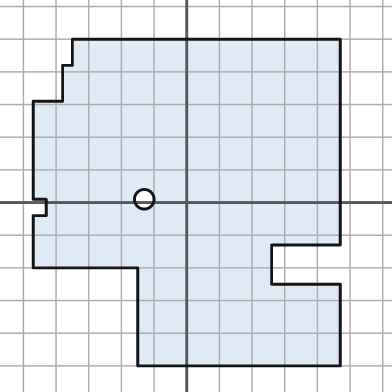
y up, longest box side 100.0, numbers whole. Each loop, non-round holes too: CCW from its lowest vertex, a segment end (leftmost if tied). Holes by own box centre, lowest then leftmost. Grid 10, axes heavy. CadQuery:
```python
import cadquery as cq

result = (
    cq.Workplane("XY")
    .moveTo(-15.0, -50.0)
    .lineTo(47.0, -50.0)
    .lineTo(47.0, -25.0)
    .lineTo(26.0, -25.0)
    .lineTo(26.0, -13.0)
    .lineTo(47.0, -13.0)
    .lineTo(47.0, 50.0)
    .lineTo(-35.0, 50.0)
    .lineTo(-35.0, 42.0)
    .lineTo(-38.0, 42.0)
    .lineTo(-38.0, 31.0)
    .lineTo(-47.0, 31.0)
    .lineTo(-47.0, 1.0)
    .lineTo(-43.0, 1.0)
    .lineTo(-43.0, -4.0)
    .lineTo(-47.0, -4.0)
    .lineTo(-47.0, -20.0)
    .lineTo(-15.0, -20.0)
    .close()
    .moveTo(-13.0, 1.0)
    .circle(3.0)
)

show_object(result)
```